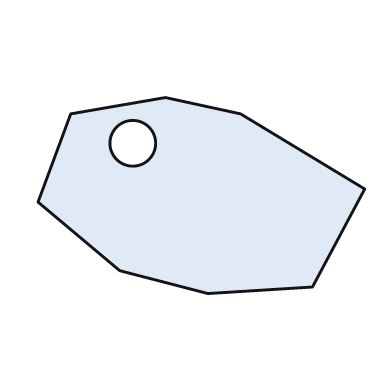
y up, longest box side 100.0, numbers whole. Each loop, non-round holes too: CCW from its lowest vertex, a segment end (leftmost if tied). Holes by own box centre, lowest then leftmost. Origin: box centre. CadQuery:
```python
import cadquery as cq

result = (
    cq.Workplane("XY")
    .moveTo(2.0, -30.0)
    .lineTo(34.0, -28.0)
    .lineTo(50.0, 2.0)
    .lineTo(12.0, 25.0)
    .lineTo(-11.0, 30.0)
    .lineTo(-40.0, 25.0)
    .lineTo(-50.0, -2.0)
    .lineTo(-25.0, -23.0)
    .close()
    .moveTo(-21.0, 16.0)
    .circle(7.0)
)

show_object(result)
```